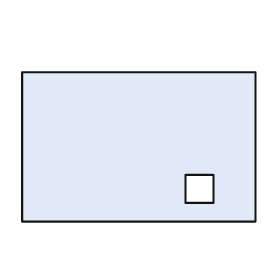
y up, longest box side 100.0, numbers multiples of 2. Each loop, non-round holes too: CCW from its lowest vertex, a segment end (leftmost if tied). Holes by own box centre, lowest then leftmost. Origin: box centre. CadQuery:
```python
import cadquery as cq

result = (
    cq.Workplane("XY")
    .moveTo(-50.0, -32.0)
    .lineTo(50.0, -32.0)
    .lineTo(50.0, 32.0)
    .lineTo(-50.0, 32.0)
    .close()
    .moveTo(20.0, -24.0)
    .lineTo(32.0, -24.0)
    .lineTo(32.0, -12.0)
    .lineTo(20.0, -12.0)
    .close()
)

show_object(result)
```